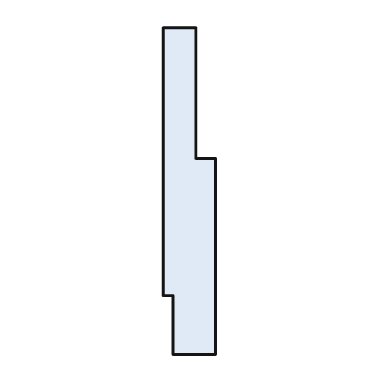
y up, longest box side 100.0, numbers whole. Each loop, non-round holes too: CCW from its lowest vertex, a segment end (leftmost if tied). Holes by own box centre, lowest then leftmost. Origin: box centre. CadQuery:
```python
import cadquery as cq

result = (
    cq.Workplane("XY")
    .moveTo(-5.0, -50.0)
    .lineTo(8.0, -50.0)
    .lineTo(8.0, 10.0)
    .lineTo(2.0, 10.0)
    .lineTo(2.0, 50.0)
    .lineTo(-8.0, 50.0)
    .lineTo(-8.0, -32.0)
    .lineTo(-5.0, -32.0)
    .close()
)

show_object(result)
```